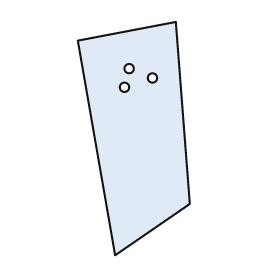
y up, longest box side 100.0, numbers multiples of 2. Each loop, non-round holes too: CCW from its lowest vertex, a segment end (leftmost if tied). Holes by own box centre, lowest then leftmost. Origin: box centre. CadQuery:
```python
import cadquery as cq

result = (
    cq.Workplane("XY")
    .moveTo(-8.0, -50.0)
    .lineTo(24.0, -28.0)
    .lineTo(18.0, 50.0)
    .lineTo(-24.0, 42.0)
    .close()
    .moveTo(-4.0, 22.0)
    .circle(2.0)
    .moveTo(8.0, 26.0)
    .circle(2.0)
    .moveTo(-2.0, 30.0)
    .circle(2.0)
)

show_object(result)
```